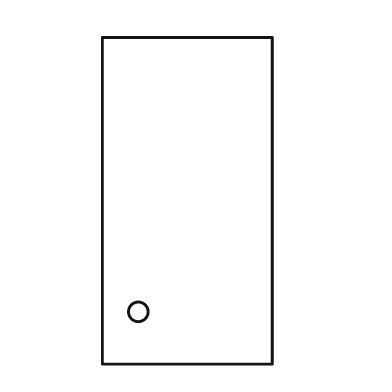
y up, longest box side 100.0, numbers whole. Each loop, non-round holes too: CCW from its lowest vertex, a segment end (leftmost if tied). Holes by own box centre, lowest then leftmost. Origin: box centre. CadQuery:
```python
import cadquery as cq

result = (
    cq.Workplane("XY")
    .moveTo(-26.0, -50.0)
    .lineTo(26.0, -50.0)
    .lineTo(26.0, 50.0)
    .lineTo(-26.0, 50.0)
    .close()
    .moveTo(-15.0, -34.0)
    .circle(3.0)
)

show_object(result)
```